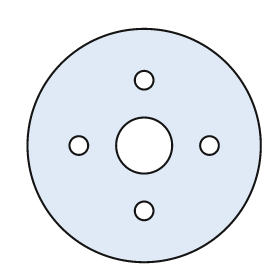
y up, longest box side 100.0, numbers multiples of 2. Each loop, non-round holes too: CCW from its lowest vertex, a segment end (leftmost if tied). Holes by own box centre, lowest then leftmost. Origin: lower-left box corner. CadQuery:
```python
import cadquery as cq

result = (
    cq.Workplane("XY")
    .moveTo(50.0, 50.0)
    .circle(50.0)
    .moveTo(50.0, 22.0)
    .circle(4.0)
    .moveTo(22.0, 50.0)
    .circle(4.0)
    .moveTo(50.0, 50.0)
    .circle(12.0)
    .moveTo(78.0, 50.0)
    .circle(4.0)
    .moveTo(50.0, 78.0)
    .circle(4.0)
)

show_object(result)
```